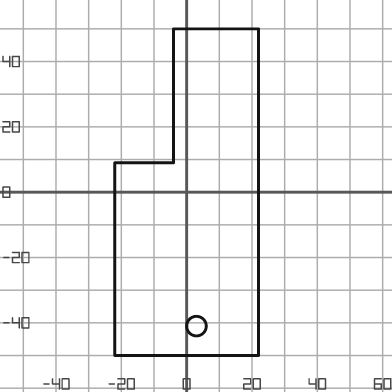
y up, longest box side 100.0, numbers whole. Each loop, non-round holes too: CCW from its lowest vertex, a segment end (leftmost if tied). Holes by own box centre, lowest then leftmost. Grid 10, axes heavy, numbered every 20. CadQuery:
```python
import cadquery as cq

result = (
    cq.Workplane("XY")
    .moveTo(-22.0, -50.0)
    .lineTo(22.0, -50.0)
    .lineTo(22.0, 50.0)
    .lineTo(-4.0, 50.0)
    .lineTo(-4.0, 9.0)
    .lineTo(-22.0, 9.0)
    .close()
    .moveTo(3.0, -41.0)
    .circle(3.0)
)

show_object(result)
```